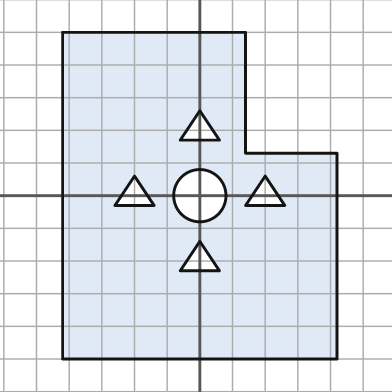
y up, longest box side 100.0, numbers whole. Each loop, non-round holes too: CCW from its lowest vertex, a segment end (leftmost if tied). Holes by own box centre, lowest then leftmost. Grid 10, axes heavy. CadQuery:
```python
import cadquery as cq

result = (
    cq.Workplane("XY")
    .moveTo(-42.0, -50.0)
    .lineTo(42.0, -50.0)
    .lineTo(42.0, 13.0)
    .lineTo(14.0, 13.0)
    .lineTo(14.0, 50.0)
    .lineTo(-42.0, 50.0)
    .close()
    .moveTo(-6.0, -23.0)
    .lineTo(6.0, -23.0)
    .lineTo(0.0, -14.0)
    .close()
    .moveTo(0.0, 0.0)
    .circle(8.0)
    .moveTo(-26.0, -3.0)
    .lineTo(-14.0, -3.0)
    .lineTo(-20.0, 6.0)
    .close()
    .moveTo(14.0, -3.0)
    .lineTo(26.0, -3.0)
    .lineTo(20.0, 6.0)
    .close()
    .moveTo(-6.0, 17.0)
    .lineTo(6.0, 17.0)
    .lineTo(0.0, 26.0)
    .close()
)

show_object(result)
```